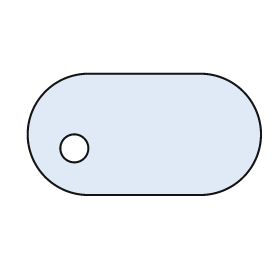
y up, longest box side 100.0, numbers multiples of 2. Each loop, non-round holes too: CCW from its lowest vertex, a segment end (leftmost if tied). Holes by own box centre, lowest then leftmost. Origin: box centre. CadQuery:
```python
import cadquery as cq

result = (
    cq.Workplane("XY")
    .moveTo(-24.0, -26.0)
    .lineTo(24.0, -26.0)
    .threePointArc((50.0, 0.0), (24.0, 26.0))
    .lineTo(-24.0, 26.0)
    .threePointArc((-50.0, 0.0), (-24.0, -26.0))
    .close()
    .moveTo(-30.0, -6.0)
    .circle(6.0)
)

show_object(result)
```